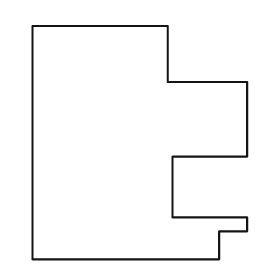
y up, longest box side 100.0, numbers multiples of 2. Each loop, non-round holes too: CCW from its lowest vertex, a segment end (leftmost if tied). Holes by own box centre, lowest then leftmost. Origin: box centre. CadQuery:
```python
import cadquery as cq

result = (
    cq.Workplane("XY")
    .moveTo(-46.0, -50.0)
    .lineTo(34.0, -50.0)
    .lineTo(34.0, -38.0)
    .lineTo(46.0, -38.0)
    .lineTo(46.0, -32.0)
    .lineTo(14.0, -32.0)
    .lineTo(14.0, -6.0)
    .lineTo(46.0, -6.0)
    .lineTo(46.0, 26.0)
    .lineTo(12.0, 26.0)
    .lineTo(12.0, 50.0)
    .lineTo(-46.0, 50.0)
    .close()
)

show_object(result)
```